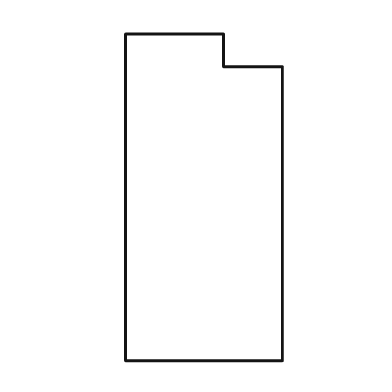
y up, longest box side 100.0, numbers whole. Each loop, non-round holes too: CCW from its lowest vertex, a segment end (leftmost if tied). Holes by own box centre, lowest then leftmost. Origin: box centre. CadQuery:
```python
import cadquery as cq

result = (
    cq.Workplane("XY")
    .moveTo(-24.0, -50.0)
    .lineTo(24.0, -50.0)
    .lineTo(24.0, 40.0)
    .lineTo(6.0, 40.0)
    .lineTo(6.0, 50.0)
    .lineTo(-24.0, 50.0)
    .close()
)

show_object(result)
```